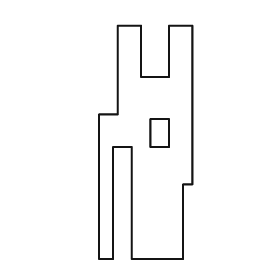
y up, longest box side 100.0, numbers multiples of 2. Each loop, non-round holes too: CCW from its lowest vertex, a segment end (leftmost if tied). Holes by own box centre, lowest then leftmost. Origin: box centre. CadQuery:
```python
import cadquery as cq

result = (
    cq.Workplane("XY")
    .moveTo(-20.0, -50.0)
    .lineTo(-14.0, -50.0)
    .lineTo(-14.0, -2.0)
    .lineTo(-6.0, -2.0)
    .lineTo(-6.0, -50.0)
    .lineTo(16.0, -50.0)
    .lineTo(16.0, -18.0)
    .lineTo(20.0, -18.0)
    .lineTo(20.0, 50.0)
    .lineTo(10.0, 50.0)
    .lineTo(10.0, 28.0)
    .lineTo(-2.0, 28.0)
    .lineTo(-2.0, 50.0)
    .lineTo(-12.0, 50.0)
    .lineTo(-12.0, 12.0)
    .lineTo(-20.0, 12.0)
    .close()
    .moveTo(2.0, -2.0)
    .lineTo(10.0, -2.0)
    .lineTo(10.0, 10.0)
    .lineTo(2.0, 10.0)
    .close()
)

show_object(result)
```